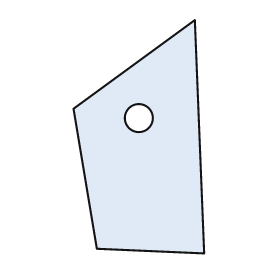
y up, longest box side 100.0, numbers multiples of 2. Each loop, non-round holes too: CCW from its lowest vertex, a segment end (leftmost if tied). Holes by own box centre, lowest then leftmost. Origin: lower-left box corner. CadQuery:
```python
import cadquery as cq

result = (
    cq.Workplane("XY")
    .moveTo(56.0, 0.0)
    .lineTo(52.0, 100.0)
    .lineTo(0.0, 62.0)
    .lineTo(10.0, 2.0)
    .close()
    .moveTo(28.0, 58.0)
    .circle(6.0)
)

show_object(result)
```